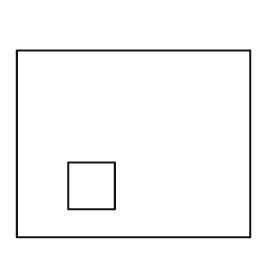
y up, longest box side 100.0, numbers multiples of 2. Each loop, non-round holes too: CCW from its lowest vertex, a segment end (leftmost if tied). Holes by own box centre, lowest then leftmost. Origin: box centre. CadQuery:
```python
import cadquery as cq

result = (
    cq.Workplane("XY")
    .moveTo(-50.0, -40.0)
    .lineTo(50.0, -40.0)
    .lineTo(50.0, 40.0)
    .lineTo(-50.0, 40.0)
    .close()
    .moveTo(-28.0, -28.0)
    .lineTo(-8.0, -28.0)
    .lineTo(-8.0, -8.0)
    .lineTo(-28.0, -8.0)
    .close()
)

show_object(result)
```